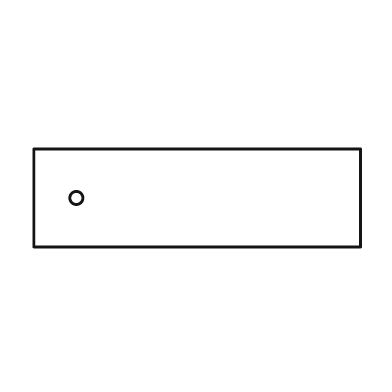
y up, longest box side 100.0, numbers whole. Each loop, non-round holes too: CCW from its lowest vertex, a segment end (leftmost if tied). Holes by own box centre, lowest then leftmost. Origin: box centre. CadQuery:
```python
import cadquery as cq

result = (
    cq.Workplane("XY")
    .moveTo(-50.0, -15.0)
    .lineTo(50.0, -15.0)
    .lineTo(50.0, 15.0)
    .lineTo(-50.0, 15.0)
    .close()
    .moveTo(-37.0, 0.0)
    .circle(2.0)
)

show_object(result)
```